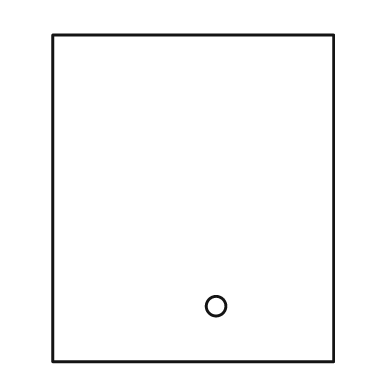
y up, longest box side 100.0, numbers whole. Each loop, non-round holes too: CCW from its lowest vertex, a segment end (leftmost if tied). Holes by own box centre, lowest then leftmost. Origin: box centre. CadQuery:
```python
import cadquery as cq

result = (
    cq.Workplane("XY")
    .moveTo(-43.0, -50.0)
    .lineTo(43.0, -50.0)
    .lineTo(43.0, 50.0)
    .lineTo(-43.0, 50.0)
    .close()
    .moveTo(7.0, -33.0)
    .circle(3.0)
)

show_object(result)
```